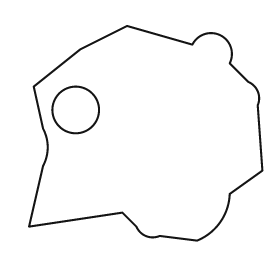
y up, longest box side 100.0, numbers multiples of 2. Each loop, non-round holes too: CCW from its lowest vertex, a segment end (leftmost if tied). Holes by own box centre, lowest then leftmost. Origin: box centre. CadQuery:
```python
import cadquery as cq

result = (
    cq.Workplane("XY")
    .moveTo(22.0, -46.0)
    .threePointArc((32.0, -38.0), (36.0, -26.0))
    .lineTo(50.0, -16.0)
    .lineTo(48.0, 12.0)
    .threePointArc((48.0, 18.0), (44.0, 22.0))
    .lineTo(36.0, 30.0)
    .threePointArc((32.0, 42.0), (20.0, 38.0))
    .lineTo(-8.0, 46.0)
    .lineTo(-28.0, 36.0)
    .lineTo(-48.0, 20.0)
    .lineTo(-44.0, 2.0)
    .threePointArc((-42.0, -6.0), (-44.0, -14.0))
    .lineTo(-50.0, -40.0)
    .lineTo(-10.0, -34.0)
    .lineTo(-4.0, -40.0)
    .threePointArc((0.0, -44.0), (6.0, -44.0))
    .close()
    .moveTo(-30.0, 10.0)
    .circle(10.0)
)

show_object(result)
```